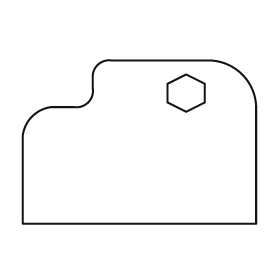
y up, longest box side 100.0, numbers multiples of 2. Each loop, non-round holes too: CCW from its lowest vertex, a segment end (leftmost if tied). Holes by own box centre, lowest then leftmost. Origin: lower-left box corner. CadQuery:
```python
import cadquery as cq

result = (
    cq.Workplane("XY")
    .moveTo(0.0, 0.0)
    .lineTo(100.0, 0.0)
    .lineTo(100.0, 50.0)
    .threePointArc((94.0, 64.0), (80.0, 70.0))
    .lineTo(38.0, 70.0)
    .threePointArc((32.0, 68.0), (30.0, 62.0))
    .lineTo(30.0, 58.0)
    .threePointArc((28.0, 52.0), (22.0, 50.0))
    .lineTo(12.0, 50.0)
    .threePointArc((4.0, 46.0), (0.0, 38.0))
    .close()
    .moveTo(70.0, 48.0)
    .lineTo(78.0, 52.0)
    .lineTo(78.0, 60.0)
    .lineTo(70.0, 64.0)
    .lineTo(62.0, 60.0)
    .lineTo(62.0, 52.0)
    .close()
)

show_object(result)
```